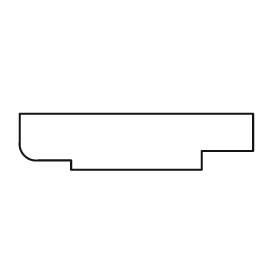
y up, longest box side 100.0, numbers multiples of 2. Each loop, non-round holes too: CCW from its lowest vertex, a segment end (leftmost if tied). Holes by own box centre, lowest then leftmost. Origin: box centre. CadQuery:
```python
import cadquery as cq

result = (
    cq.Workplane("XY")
    .moveTo(-28.0, -12.0)
    .lineTo(28.0, -12.0)
    .lineTo(28.0, -4.0)
    .lineTo(50.0, -4.0)
    .lineTo(50.0, 12.0)
    .lineTo(-50.0, 12.0)
    .lineTo(-50.0, 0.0)
    .threePointArc((-48.0, -6.0), (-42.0, -8.0))
    .lineTo(-28.0, -8.0)
    .close()
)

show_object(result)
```